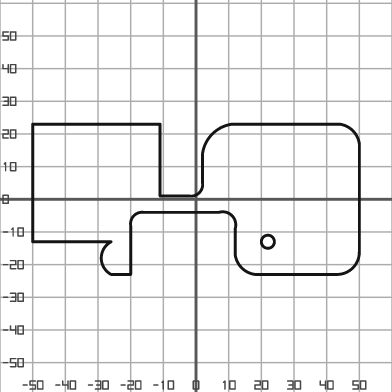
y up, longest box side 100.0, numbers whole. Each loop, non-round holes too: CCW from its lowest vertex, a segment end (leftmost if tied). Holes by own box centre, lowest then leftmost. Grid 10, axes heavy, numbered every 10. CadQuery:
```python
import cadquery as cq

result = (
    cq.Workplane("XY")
    .moveTo(-26.0, -23.0)
    .lineTo(-20.0, -23.0)
    .lineTo(-20.0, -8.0)
    .threePointArc((-19.0, -5.0), (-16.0, -4.0))
    .lineTo(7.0, -4.0)
    .threePointArc((11.0, -5.0), (12.0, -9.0))
    .lineTo(12.0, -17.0)
    .threePointArc((14.0, -21.0), (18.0, -23.0))
    .lineTo(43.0, -23.0)
    .threePointArc((48.0, -21.0), (50.0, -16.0))
    .lineTo(50.0, 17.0)
    .threePointArc((48.0, 21.0), (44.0, 23.0))
    .lineTo(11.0, 23.0)
    .threePointArc((5.0, 20.0), (2.0, 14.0))
    .lineTo(2.0, 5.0)
    .threePointArc((1.0, 2.0), (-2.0, 1.0))
    .lineTo(-11.0, 1.0)
    .lineTo(-11.0, 23.0)
    .lineTo(-50.0, 23.0)
    .lineTo(-50.0, -13.0)
    .lineTo(-26.0, -13.0)
    .threePointArc((-29.0, -18.0), (-26.0, -23.0))
    .close()
    .moveTo(22.0, -13.0)
    .circle(2.0)
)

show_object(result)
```